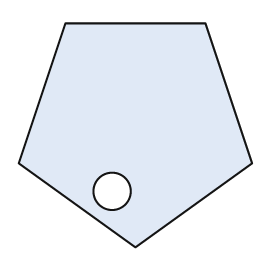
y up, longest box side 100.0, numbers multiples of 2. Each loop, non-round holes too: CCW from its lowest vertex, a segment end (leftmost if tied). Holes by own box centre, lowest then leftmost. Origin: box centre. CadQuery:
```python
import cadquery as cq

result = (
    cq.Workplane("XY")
    .moveTo(0.0, -48.0)
    .lineTo(50.0, -12.0)
    .lineTo(30.0, 48.0)
    .lineTo(-30.0, 48.0)
    .lineTo(-50.0, -12.0)
    .close()
    .moveTo(-10.0, -24.0)
    .circle(8.0)
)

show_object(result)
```